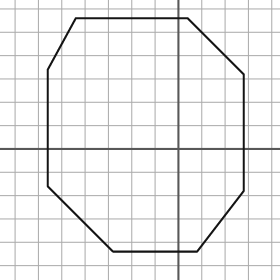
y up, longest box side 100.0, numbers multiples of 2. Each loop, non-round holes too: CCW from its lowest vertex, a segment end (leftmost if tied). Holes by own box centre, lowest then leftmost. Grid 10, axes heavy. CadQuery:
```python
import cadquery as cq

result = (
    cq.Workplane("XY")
    .moveTo(-28.0, -44.0)
    .lineTo(8.0, -44.0)
    .lineTo(28.0, -18.0)
    .lineTo(28.0, 32.0)
    .lineTo(4.0, 56.0)
    .lineTo(-44.0, 56.0)
    .lineTo(-56.0, 34.0)
    .lineTo(-56.0, -16.0)
    .close()
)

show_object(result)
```